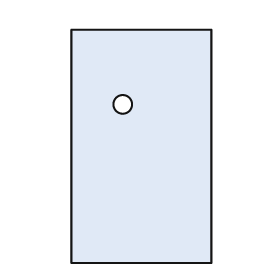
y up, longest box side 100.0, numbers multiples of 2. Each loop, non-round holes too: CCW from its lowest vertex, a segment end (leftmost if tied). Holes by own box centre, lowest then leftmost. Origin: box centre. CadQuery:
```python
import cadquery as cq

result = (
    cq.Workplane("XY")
    .moveTo(-30.0, -50.0)
    .lineTo(30.0, -50.0)
    .lineTo(30.0, 50.0)
    .lineTo(-30.0, 50.0)
    .close()
    .moveTo(-8.0, 18.0)
    .circle(4.0)
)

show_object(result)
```